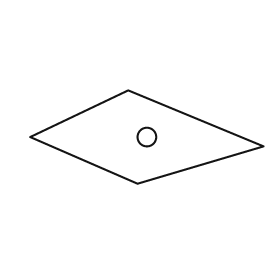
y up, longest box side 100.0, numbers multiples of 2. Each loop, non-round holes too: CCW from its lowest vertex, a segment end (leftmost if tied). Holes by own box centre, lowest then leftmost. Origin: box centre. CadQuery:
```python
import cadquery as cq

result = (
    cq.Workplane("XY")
    .moveTo(-4.0, -20.0)
    .lineTo(50.0, -4.0)
    .lineTo(-8.0, 20.0)
    .lineTo(-50.0, 0.0)
    .close()
    .moveTo(0.0, 0.0)
    .circle(4.0)
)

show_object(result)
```